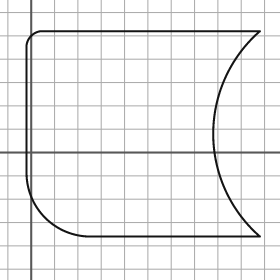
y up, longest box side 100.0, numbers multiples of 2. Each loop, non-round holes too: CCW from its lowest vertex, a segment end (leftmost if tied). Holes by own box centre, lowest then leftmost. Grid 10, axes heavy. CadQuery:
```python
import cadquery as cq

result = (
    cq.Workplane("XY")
    .moveTo(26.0, -36.0)
    .lineTo(98.0, -36.0)
    .threePointArc((78.0, 8.0), (98.0, 52.0))
    .lineTo(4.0, 52.0)
    .threePointArc((0.0, 50.0), (-2.0, 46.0))
    .lineTo(-2.0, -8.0)
    .threePointArc((6.0, -28.0), (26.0, -36.0))
    .close()
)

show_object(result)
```